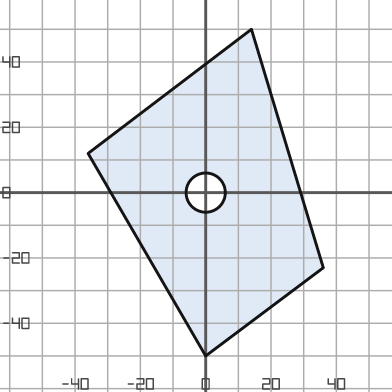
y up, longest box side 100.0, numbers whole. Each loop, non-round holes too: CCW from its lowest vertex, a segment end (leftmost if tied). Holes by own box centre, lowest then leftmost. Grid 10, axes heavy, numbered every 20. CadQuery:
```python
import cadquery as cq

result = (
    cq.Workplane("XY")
    .moveTo(0.0, -50.0)
    .lineTo(36.0, -23.0)
    .lineTo(14.0, 50.0)
    .lineTo(-36.0, 12.0)
    .close()
    .moveTo(0.0, 0.0)
    .circle(6.0)
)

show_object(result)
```